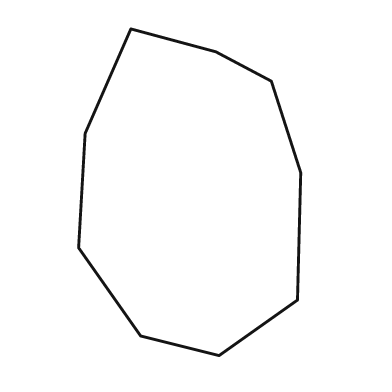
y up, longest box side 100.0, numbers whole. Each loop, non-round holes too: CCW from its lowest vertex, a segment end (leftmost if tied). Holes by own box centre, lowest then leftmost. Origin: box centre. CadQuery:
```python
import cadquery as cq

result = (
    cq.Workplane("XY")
    .moveTo(9.0, -50.0)
    .lineTo(33.0, -33.0)
    .lineTo(34.0, 6.0)
    .lineTo(25.0, 34.0)
    .lineTo(8.0, 43.0)
    .lineTo(-18.0, 50.0)
    .lineTo(-32.0, 18.0)
    .lineTo(-34.0, -17.0)
    .lineTo(-15.0, -44.0)
    .close()
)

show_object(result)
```